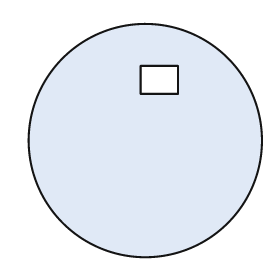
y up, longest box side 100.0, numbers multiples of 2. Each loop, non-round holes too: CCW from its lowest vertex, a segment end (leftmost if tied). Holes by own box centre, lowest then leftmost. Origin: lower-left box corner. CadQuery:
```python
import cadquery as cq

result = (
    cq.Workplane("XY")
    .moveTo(50.0, 50.0)
    .circle(50.0)
    .moveTo(48.0, 70.0)
    .lineTo(64.0, 70.0)
    .lineTo(64.0, 82.0)
    .lineTo(48.0, 82.0)
    .close()
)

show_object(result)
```